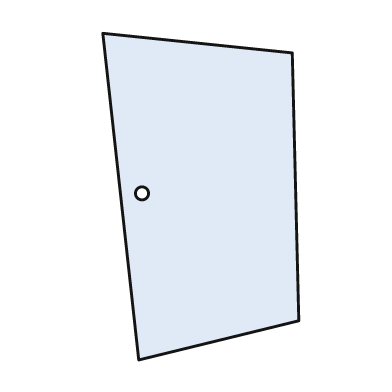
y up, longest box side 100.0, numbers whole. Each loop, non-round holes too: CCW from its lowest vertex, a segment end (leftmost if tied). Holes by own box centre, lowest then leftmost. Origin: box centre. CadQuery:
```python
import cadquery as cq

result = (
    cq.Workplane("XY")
    .moveTo(-19.0, -50.0)
    .lineTo(30.0, -38.0)
    .lineTo(28.0, 44.0)
    .lineTo(-30.0, 50.0)
    .close()
    .moveTo(-18.0, 1.0)
    .circle(2.0)
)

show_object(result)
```